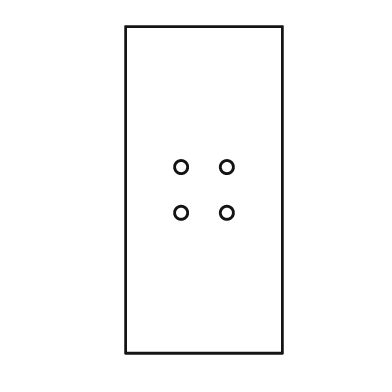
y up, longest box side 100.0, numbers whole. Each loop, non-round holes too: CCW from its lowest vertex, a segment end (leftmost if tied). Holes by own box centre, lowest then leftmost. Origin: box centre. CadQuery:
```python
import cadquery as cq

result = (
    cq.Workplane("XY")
    .moveTo(-24.0, -50.0)
    .lineTo(24.0, -50.0)
    .lineTo(24.0, 50.0)
    .lineTo(-24.0, 50.0)
    .close()
    .moveTo(-7.0, -7.0)
    .circle(2.0)
    .moveTo(7.0, -7.0)
    .circle(2.0)
    .moveTo(-7.0, 7.0)
    .circle(2.0)
    .moveTo(7.0, 7.0)
    .circle(2.0)
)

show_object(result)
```